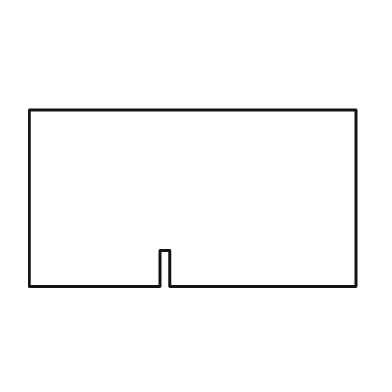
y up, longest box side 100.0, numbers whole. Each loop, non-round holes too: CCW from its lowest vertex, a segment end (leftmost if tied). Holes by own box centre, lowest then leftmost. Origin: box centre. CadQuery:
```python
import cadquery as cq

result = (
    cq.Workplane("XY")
    .moveTo(-50.0, -27.0)
    .lineTo(-10.0, -27.0)
    .lineTo(-10.0, -16.0)
    .lineTo(-7.0, -16.0)
    .lineTo(-7.0, -27.0)
    .lineTo(50.0, -27.0)
    .lineTo(50.0, 27.0)
    .lineTo(-50.0, 27.0)
    .close()
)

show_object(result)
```